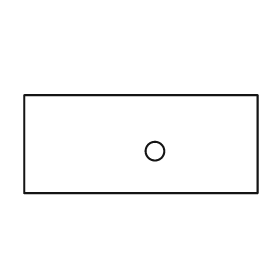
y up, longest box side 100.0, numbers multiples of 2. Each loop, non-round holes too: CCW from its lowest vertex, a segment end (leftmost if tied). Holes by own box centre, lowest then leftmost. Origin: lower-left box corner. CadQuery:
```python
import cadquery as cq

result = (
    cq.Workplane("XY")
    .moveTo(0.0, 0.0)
    .lineTo(100.0, 0.0)
    .lineTo(100.0, 42.0)
    .lineTo(0.0, 42.0)
    .close()
    .moveTo(56.0, 18.0)
    .circle(4.0)
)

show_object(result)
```